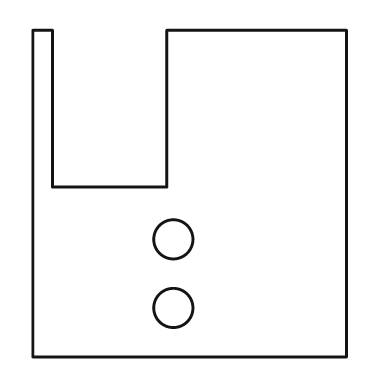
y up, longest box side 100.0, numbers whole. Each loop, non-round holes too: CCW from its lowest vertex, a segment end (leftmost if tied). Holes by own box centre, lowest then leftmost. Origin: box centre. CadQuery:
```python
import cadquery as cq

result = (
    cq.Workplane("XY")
    .moveTo(-48.0, -50.0)
    .lineTo(48.0, -50.0)
    .lineTo(48.0, 50.0)
    .lineTo(-7.0, 50.0)
    .lineTo(-7.0, 2.0)
    .lineTo(-42.0, 2.0)
    .lineTo(-42.0, 50.0)
    .lineTo(-48.0, 50.0)
    .close()
    .moveTo(-5.0, -35.0)
    .circle(6.0)
    .moveTo(-5.0, -14.0)
    .circle(6.0)
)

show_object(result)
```